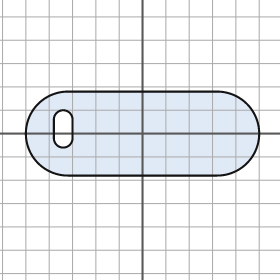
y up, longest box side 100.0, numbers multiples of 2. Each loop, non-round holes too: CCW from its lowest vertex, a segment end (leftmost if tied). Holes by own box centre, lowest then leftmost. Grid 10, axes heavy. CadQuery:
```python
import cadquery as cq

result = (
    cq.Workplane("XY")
    .moveTo(-32.0, -18.0)
    .lineTo(32.0, -18.0)
    .threePointArc((50.0, 0.0), (32.0, 18.0))
    .lineTo(-32.0, 18.0)
    .threePointArc((-50.0, 0.0), (-32.0, -18.0))
    .close()
    .moveTo(-38.0, -2.0)
    .threePointArc((-34.0, -6.0), (-30.0, -2.0))
    .lineTo(-30.0, 6.0)
    .threePointArc((-34.0, 10.0), (-38.0, 6.0))
    .close()
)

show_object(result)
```